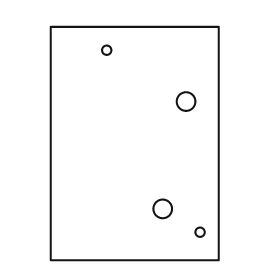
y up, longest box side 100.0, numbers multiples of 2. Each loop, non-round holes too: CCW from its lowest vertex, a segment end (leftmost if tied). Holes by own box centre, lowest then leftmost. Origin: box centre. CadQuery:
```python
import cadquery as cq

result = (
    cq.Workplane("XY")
    .moveTo(-36.0, -50.0)
    .lineTo(36.0, -50.0)
    .lineTo(36.0, 50.0)
    .lineTo(-36.0, 50.0)
    .close()
    .moveTo(28.0, -38.0)
    .circle(2.0)
    .moveTo(12.0, -28.0)
    .circle(4.0)
    .moveTo(22.0, 18.0)
    .circle(4.0)
    .moveTo(-12.0, 40.0)
    .circle(2.0)
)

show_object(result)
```